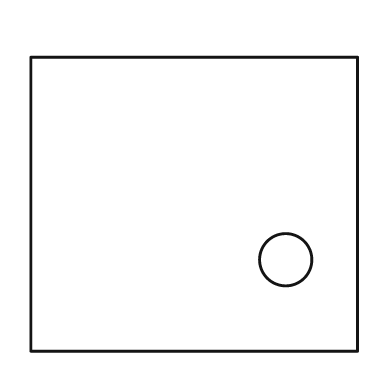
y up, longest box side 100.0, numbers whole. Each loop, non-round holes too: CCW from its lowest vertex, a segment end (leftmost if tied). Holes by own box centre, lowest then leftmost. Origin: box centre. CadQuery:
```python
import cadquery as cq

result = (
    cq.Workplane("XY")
    .moveTo(-50.0, -45.0)
    .lineTo(50.0, -45.0)
    .lineTo(50.0, 45.0)
    .lineTo(-50.0, 45.0)
    .close()
    .moveTo(28.0, -17.0)
    .circle(8.0)
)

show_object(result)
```